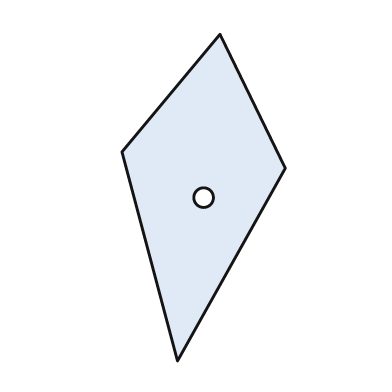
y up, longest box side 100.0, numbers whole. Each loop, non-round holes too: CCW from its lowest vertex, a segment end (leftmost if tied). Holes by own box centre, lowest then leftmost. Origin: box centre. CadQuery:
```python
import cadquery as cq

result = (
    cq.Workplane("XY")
    .moveTo(-8.0, -50.0)
    .lineTo(25.0, 9.0)
    .lineTo(5.0, 50.0)
    .lineTo(-25.0, 14.0)
    .close()
    .moveTo(0.0, 0.0)
    .circle(3.0)
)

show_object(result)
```